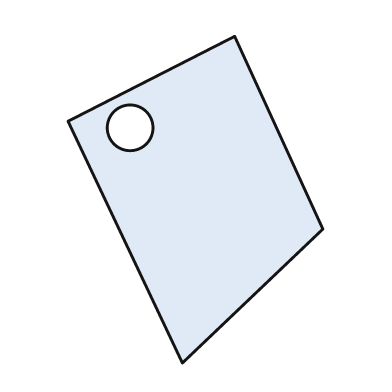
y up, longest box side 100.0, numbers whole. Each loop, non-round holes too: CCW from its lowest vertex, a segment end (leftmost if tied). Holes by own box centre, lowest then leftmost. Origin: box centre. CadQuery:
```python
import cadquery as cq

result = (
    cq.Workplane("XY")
    .moveTo(-4.0, -50.0)
    .lineTo(39.0, -9.0)
    .lineTo(12.0, 50.0)
    .lineTo(-39.0, 24.0)
    .close()
    .moveTo(-20.0, 22.0)
    .circle(7.0)
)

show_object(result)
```